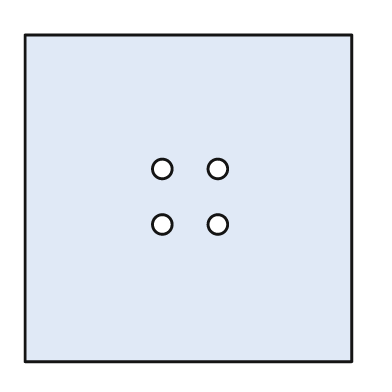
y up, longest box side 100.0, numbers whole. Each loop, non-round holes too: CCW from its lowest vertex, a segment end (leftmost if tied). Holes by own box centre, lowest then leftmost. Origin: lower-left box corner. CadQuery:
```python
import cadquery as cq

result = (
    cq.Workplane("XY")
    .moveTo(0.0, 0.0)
    .lineTo(100.0, 0.0)
    .lineTo(100.0, 100.0)
    .lineTo(0.0, 100.0)
    .close()
    .moveTo(42.0, 42.0)
    .circle(3.0)
    .moveTo(59.0, 42.0)
    .circle(3.0)
    .moveTo(42.0, 59.0)
    .circle(3.0)
    .moveTo(59.0, 59.0)
    .circle(3.0)
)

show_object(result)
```